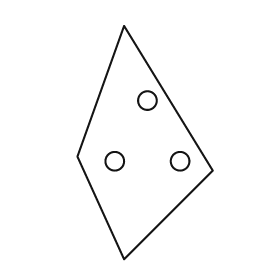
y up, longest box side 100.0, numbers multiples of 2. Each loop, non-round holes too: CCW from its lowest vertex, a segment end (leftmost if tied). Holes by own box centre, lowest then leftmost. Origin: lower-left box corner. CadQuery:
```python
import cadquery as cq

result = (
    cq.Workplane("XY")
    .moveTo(20.0, 0.0)
    .lineTo(58.0, 38.0)
    .lineTo(20.0, 100.0)
    .lineTo(0.0, 44.0)
    .close()
    .moveTo(16.0, 42.0)
    .circle(4.0)
    .moveTo(44.0, 42.0)
    .circle(4.0)
    .moveTo(30.0, 68.0)
    .circle(4.0)
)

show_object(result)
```